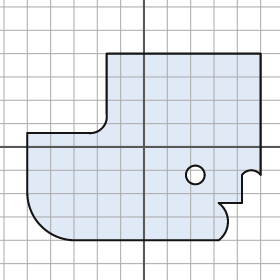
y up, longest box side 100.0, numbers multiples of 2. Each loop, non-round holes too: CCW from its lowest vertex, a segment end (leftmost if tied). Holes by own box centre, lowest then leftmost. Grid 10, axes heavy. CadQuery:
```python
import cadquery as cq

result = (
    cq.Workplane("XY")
    .moveTo(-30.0, -40.0)
    .lineTo(32.0, -40.0)
    .threePointArc((36.0, -32.0), (32.0, -24.0))
    .lineTo(42.0, -24.0)
    .lineTo(42.0, -12.0)
    .threePointArc((46.0, -10.0), (50.0, -12.0))
    .lineTo(50.0, 40.0)
    .lineTo(-16.0, 40.0)
    .lineTo(-16.0, 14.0)
    .threePointArc((-18.0, 8.0), (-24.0, 6.0))
    .lineTo(-50.0, 6.0)
    .lineTo(-50.0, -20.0)
    .threePointArc((-44.0, -34.0), (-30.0, -40.0))
    .close()
    .moveTo(22.0, -12.0)
    .circle(4.0)
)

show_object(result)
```